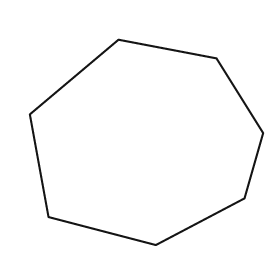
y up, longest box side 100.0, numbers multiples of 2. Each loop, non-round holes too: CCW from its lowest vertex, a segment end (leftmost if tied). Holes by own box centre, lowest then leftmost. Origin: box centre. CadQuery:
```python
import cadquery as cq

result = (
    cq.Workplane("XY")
    .moveTo(4.0, -44.0)
    .lineTo(42.0, -24.0)
    .lineTo(50.0, 4.0)
    .lineTo(30.0, 36.0)
    .lineTo(-12.0, 44.0)
    .lineTo(-50.0, 12.0)
    .lineTo(-42.0, -32.0)
    .close()
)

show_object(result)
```